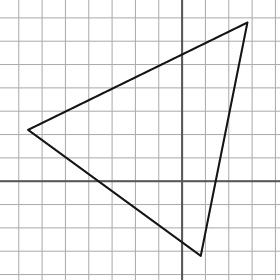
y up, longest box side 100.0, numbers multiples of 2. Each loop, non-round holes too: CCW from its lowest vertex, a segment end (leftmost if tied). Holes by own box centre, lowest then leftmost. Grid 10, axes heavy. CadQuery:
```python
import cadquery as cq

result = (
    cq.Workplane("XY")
    .moveTo(8.0, -32.0)
    .lineTo(28.0, 68.0)
    .lineTo(-66.0, 22.0)
    .close()
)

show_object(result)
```